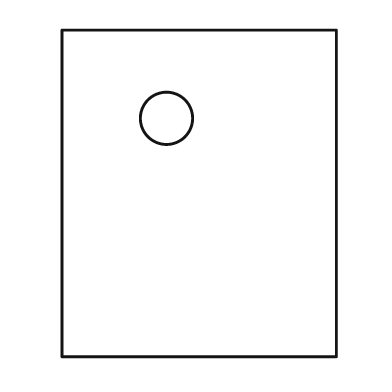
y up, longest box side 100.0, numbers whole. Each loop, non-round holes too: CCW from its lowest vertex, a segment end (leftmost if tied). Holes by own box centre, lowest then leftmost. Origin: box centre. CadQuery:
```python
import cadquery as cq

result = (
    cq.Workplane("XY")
    .moveTo(-42.0, -50.0)
    .lineTo(42.0, -50.0)
    .lineTo(42.0, 50.0)
    .lineTo(-42.0, 50.0)
    .close()
    .moveTo(-10.0, 23.0)
    .circle(8.0)
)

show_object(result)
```